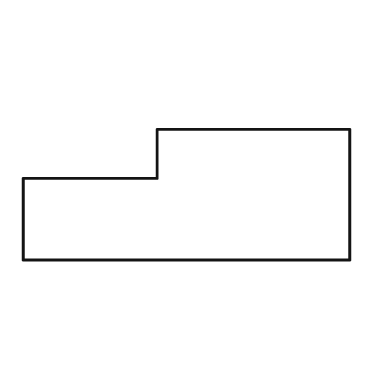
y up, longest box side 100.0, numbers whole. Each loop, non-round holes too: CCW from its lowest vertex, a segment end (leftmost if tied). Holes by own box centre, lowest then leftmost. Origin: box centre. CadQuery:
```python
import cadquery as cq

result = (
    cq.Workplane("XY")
    .moveTo(-50.0, -20.0)
    .lineTo(50.0, -20.0)
    .lineTo(50.0, 20.0)
    .lineTo(-9.0, 20.0)
    .lineTo(-9.0, 5.0)
    .lineTo(-50.0, 5.0)
    .close()
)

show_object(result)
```